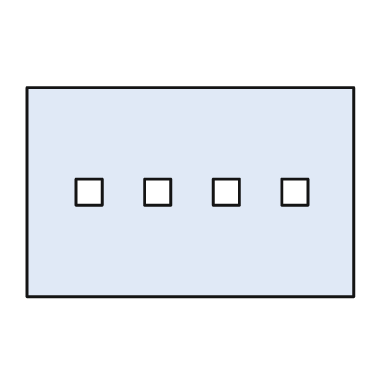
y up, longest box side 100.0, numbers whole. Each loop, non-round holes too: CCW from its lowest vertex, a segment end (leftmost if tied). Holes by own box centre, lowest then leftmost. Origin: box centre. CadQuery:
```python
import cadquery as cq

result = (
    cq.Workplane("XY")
    .moveTo(-50.0, -32.0)
    .lineTo(50.0, -32.0)
    .lineTo(50.0, 32.0)
    .lineTo(-50.0, 32.0)
    .close()
    .moveTo(-35.0, -4.0)
    .lineTo(-27.0, -4.0)
    .lineTo(-27.0, 4.0)
    .lineTo(-35.0, 4.0)
    .close()
    .moveTo(-14.0, -4.0)
    .lineTo(-6.0, -4.0)
    .lineTo(-6.0, 4.0)
    .lineTo(-14.0, 4.0)
    .close()
    .moveTo(7.0, -4.0)
    .lineTo(15.0, -4.0)
    .lineTo(15.0, 4.0)
    .lineTo(7.0, 4.0)
    .close()
    .moveTo(28.0, -4.0)
    .lineTo(36.0, -4.0)
    .lineTo(36.0, 4.0)
    .lineTo(28.0, 4.0)
    .close()
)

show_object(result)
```